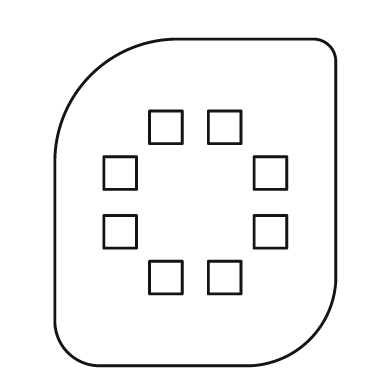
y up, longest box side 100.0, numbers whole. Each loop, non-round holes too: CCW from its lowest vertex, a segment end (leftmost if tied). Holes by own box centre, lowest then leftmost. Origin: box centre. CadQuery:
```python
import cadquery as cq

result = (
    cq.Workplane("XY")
    .moveTo(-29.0, -50.0)
    .lineTo(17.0, -50.0)
    .threePointArc((35.0, -42.0), (43.0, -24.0))
    .lineTo(43.0, 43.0)
    .threePointArc((41.0, 48.0), (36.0, 50.0))
    .lineTo(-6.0, 50.0)
    .threePointArc((-32.0, 39.0), (-43.0, 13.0))
    .lineTo(-43.0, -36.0)
    .threePointArc((-39.0, -46.0), (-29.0, -50.0))
    .close()
    .moveTo(-14.0, -28.0)
    .lineTo(-4.0, -28.0)
    .lineTo(-4.0, -18.0)
    .lineTo(-14.0, -18.0)
    .close()
    .moveTo(4.0, -28.0)
    .lineTo(14.0, -28.0)
    .lineTo(14.0, -18.0)
    .lineTo(4.0, -18.0)
    .close()
    .moveTo(-28.0, -14.0)
    .lineTo(-18.0, -14.0)
    .lineTo(-18.0, -4.0)
    .lineTo(-28.0, -4.0)
    .close()
    .moveTo(18.0, -14.0)
    .lineTo(28.0, -14.0)
    .lineTo(28.0, -4.0)
    .lineTo(18.0, -4.0)
    .close()
    .moveTo(-28.0, 4.0)
    .lineTo(-18.0, 4.0)
    .lineTo(-18.0, 14.0)
    .lineTo(-28.0, 14.0)
    .close()
    .moveTo(18.0, 4.0)
    .lineTo(28.0, 4.0)
    .lineTo(28.0, 14.0)
    .lineTo(18.0, 14.0)
    .close()
    .moveTo(-14.0, 18.0)
    .lineTo(-4.0, 18.0)
    .lineTo(-4.0, 28.0)
    .lineTo(-14.0, 28.0)
    .close()
    .moveTo(4.0, 18.0)
    .lineTo(14.0, 18.0)
    .lineTo(14.0, 28.0)
    .lineTo(4.0, 28.0)
    .close()
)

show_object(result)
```